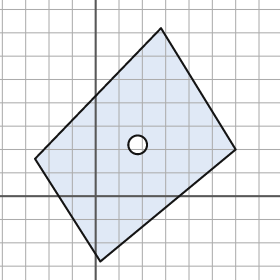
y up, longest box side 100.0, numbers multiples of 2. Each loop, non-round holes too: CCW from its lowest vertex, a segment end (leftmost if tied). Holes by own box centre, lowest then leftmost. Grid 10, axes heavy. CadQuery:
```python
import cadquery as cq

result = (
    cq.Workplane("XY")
    .moveTo(2.0, -28.0)
    .lineTo(60.0, 20.0)
    .lineTo(28.0, 72.0)
    .lineTo(-26.0, 16.0)
    .close()
    .moveTo(18.0, 22.0)
    .circle(4.0)
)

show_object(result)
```